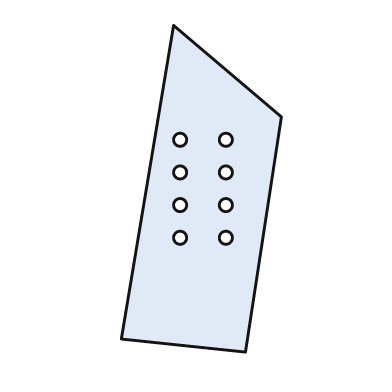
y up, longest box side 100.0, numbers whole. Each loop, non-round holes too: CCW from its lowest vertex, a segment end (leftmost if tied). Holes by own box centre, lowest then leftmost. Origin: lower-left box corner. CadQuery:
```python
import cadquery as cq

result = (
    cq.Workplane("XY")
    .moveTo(38.0, 0.0)
    .lineTo(49.0, 72.0)
    .lineTo(16.0, 100.0)
    .lineTo(0.0, 4.0)
    .close()
    .moveTo(18.0, 35.0)
    .circle(2.0)
    .moveTo(32.0, 35.0)
    .circle(2.0)
    .moveTo(18.0, 45.0)
    .circle(2.0)
    .moveTo(32.0, 45.0)
    .circle(2.0)
    .moveTo(18.0, 55.0)
    .circle(2.0)
    .moveTo(32.0, 55.0)
    .circle(2.0)
    .moveTo(18.0, 65.0)
    .circle(2.0)
    .moveTo(32.0, 65.0)
    .circle(2.0)
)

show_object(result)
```